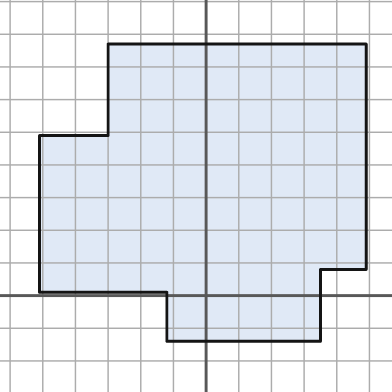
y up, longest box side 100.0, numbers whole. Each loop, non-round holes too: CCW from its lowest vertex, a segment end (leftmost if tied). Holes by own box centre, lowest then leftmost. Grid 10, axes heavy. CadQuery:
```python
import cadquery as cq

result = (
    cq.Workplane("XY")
    .moveTo(-12.0, -14.0)
    .lineTo(35.0, -14.0)
    .lineTo(35.0, 8.0)
    .lineTo(49.0, 8.0)
    .lineTo(49.0, 77.0)
    .lineTo(-30.0, 77.0)
    .lineTo(-30.0, 49.0)
    .lineTo(-51.0, 49.0)
    .lineTo(-51.0, 1.0)
    .lineTo(-12.0, 1.0)
    .close()
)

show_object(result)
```